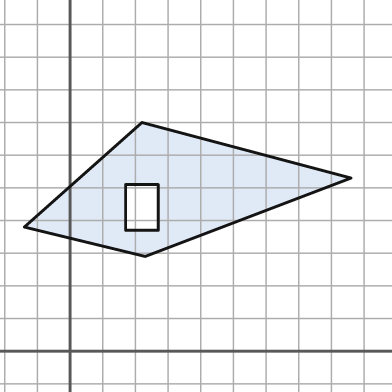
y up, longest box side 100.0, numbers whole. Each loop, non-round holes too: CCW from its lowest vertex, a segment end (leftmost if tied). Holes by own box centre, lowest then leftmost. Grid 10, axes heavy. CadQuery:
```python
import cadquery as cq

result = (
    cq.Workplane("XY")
    .moveTo(23.0, 29.0)
    .lineTo(86.0, 53.0)
    .lineTo(22.0, 70.0)
    .lineTo(-14.0, 38.0)
    .close()
    .moveTo(17.0, 37.0)
    .lineTo(27.0, 37.0)
    .lineTo(27.0, 51.0)
    .lineTo(17.0, 51.0)
    .close()
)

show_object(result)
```